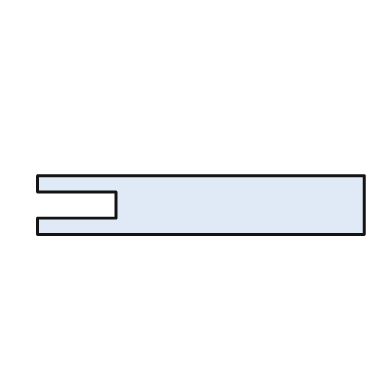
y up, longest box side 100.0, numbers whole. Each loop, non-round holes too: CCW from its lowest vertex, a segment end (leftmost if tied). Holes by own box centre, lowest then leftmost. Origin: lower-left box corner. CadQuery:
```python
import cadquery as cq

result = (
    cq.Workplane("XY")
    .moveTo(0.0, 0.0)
    .lineTo(100.0, 0.0)
    .lineTo(100.0, 18.0)
    .lineTo(0.0, 18.0)
    .lineTo(0.0, 13.0)
    .lineTo(24.0, 13.0)
    .lineTo(24.0, 5.0)
    .lineTo(0.0, 5.0)
    .close()
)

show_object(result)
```